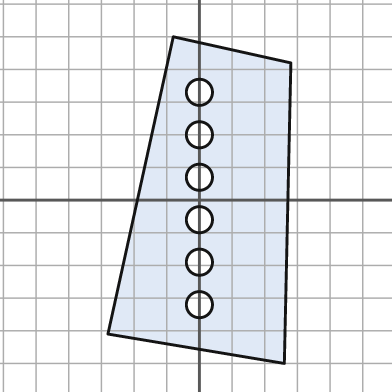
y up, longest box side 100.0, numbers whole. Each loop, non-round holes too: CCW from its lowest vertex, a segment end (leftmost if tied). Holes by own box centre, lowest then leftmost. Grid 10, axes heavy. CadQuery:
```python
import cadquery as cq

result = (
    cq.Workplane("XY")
    .moveTo(26.0, -50.0)
    .lineTo(28.0, 42.0)
    .lineTo(-8.0, 50.0)
    .lineTo(-28.0, -41.0)
    .close()
    .moveTo(0.0, -32.0)
    .circle(4.0)
    .moveTo(0.0, -19.0)
    .circle(4.0)
    .moveTo(0.0, -6.0)
    .circle(4.0)
    .moveTo(0.0, 7.0)
    .circle(4.0)
    .moveTo(0.0, 20.0)
    .circle(4.0)
    .moveTo(0.0, 33.0)
    .circle(4.0)
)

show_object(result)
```